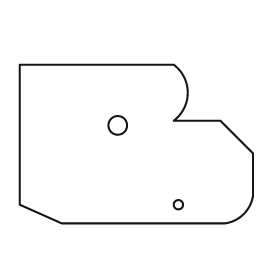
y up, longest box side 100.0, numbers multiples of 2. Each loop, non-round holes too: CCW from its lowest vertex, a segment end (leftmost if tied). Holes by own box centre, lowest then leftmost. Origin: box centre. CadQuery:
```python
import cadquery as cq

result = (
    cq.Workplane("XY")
    .moveTo(-32.0, -34.0)
    .lineTo(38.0, -34.0)
    .threePointArc((46.0, -30.0), (50.0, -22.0))
    .lineTo(50.0, -4.0)
    .lineTo(36.0, 10.0)
    .lineTo(16.0, 10.0)
    .threePointArc((22.0, 22.0), (16.0, 34.0))
    .lineTo(-50.0, 34.0)
    .lineTo(-50.0, -26.0)
    .close()
    .moveTo(18.0, -26.0)
    .circle(2.0)
    .moveTo(-8.0, 8.0)
    .circle(4.0)
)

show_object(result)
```